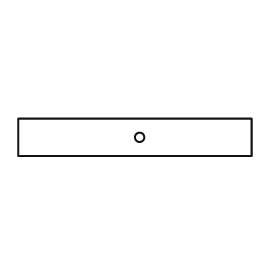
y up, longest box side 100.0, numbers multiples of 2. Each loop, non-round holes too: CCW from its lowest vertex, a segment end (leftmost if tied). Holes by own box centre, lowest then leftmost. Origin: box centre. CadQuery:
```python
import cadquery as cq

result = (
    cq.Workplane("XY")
    .moveTo(-50.0, -8.0)
    .lineTo(50.0, -8.0)
    .lineTo(50.0, 8.0)
    .lineTo(-50.0, 8.0)
    .close()
    .moveTo(2.0, 0.0)
    .circle(2.0)
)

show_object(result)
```